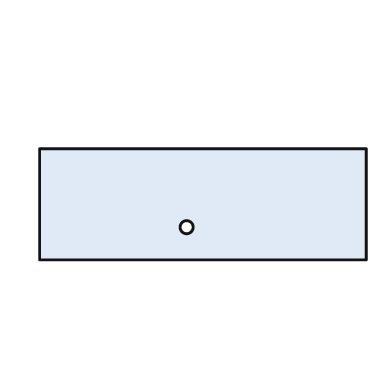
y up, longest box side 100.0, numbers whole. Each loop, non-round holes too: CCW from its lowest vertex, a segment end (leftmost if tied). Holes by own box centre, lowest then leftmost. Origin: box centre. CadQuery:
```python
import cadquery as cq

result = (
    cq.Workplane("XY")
    .moveTo(-50.0, -17.0)
    .lineTo(50.0, -17.0)
    .lineTo(50.0, 17.0)
    .lineTo(-50.0, 17.0)
    .close()
    .moveTo(-5.0, -7.0)
    .circle(2.0)
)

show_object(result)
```